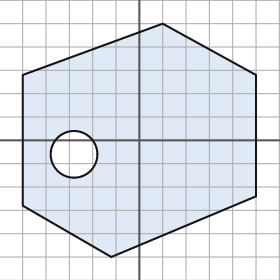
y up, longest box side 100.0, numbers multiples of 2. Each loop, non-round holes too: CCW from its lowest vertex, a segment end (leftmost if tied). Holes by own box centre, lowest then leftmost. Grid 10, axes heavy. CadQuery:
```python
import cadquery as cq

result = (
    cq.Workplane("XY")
    .moveTo(-12.0, -50.0)
    .lineTo(50.0, -24.0)
    .lineTo(50.0, 28.0)
    .lineTo(10.0, 50.0)
    .lineTo(-50.0, 28.0)
    .lineTo(-50.0, -28.0)
    .close()
    .moveTo(-28.0, -6.0)
    .circle(10.0)
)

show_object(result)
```